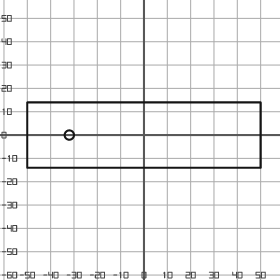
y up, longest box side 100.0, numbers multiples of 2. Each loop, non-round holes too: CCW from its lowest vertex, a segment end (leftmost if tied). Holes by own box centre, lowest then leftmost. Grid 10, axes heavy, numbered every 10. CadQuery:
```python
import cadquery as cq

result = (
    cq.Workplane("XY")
    .moveTo(-50.0, -14.0)
    .lineTo(50.0, -14.0)
    .lineTo(50.0, 14.0)
    .lineTo(-50.0, 14.0)
    .close()
    .moveTo(-32.0, 0.0)
    .circle(2.0)
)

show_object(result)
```